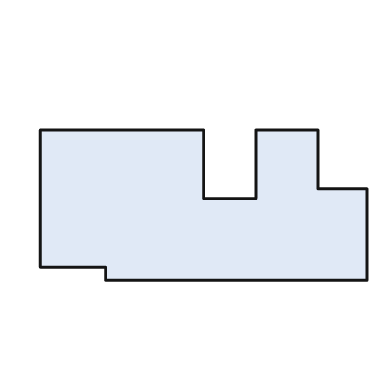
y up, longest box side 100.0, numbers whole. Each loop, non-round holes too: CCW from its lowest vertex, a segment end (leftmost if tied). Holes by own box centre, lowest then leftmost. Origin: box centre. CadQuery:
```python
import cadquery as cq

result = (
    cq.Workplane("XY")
    .moveTo(-30.0, -23.0)
    .lineTo(50.0, -23.0)
    .lineTo(50.0, 5.0)
    .lineTo(35.0, 5.0)
    .lineTo(35.0, 23.0)
    .lineTo(16.0, 23.0)
    .lineTo(16.0, 2.0)
    .lineTo(0.0, 2.0)
    .lineTo(0.0, 23.0)
    .lineTo(-50.0, 23.0)
    .lineTo(-50.0, -19.0)
    .lineTo(-30.0, -19.0)
    .close()
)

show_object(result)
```